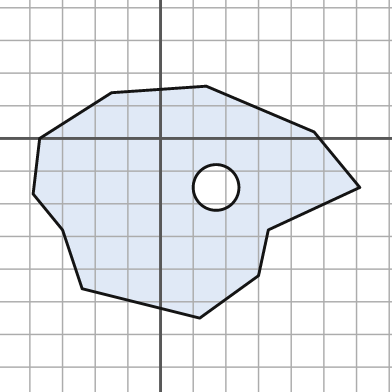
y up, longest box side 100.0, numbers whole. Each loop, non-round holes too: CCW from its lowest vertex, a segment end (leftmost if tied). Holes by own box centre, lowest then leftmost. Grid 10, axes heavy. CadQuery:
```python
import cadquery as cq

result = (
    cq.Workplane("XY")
    .moveTo(12.0, -55.0)
    .lineTo(30.0, -42.0)
    .lineTo(33.0, -28.0)
    .lineTo(61.0, -15.0)
    .lineTo(47.0, 2.0)
    .lineTo(14.0, 16.0)
    .lineTo(-15.0, 14.0)
    .lineTo(-37.0, 0.0)
    .lineTo(-39.0, -17.0)
    .lineTo(-30.0, -28.0)
    .lineTo(-24.0, -46.0)
    .close()
    .moveTo(17.0, -15.0)
    .circle(7.0)
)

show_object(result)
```